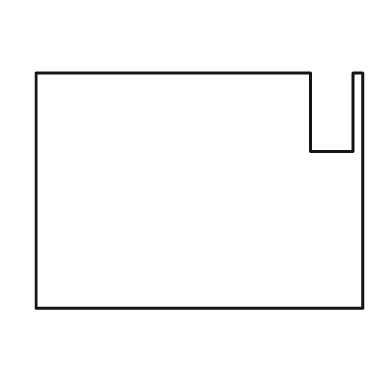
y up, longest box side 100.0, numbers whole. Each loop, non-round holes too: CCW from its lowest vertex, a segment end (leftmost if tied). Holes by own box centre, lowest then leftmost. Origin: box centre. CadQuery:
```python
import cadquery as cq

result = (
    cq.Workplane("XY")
    .moveTo(-50.0, -36.0)
    .lineTo(50.0, -36.0)
    .lineTo(50.0, 36.0)
    .lineTo(47.0, 36.0)
    .lineTo(47.0, 12.0)
    .lineTo(34.0, 12.0)
    .lineTo(34.0, 36.0)
    .lineTo(-50.0, 36.0)
    .close()
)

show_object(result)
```